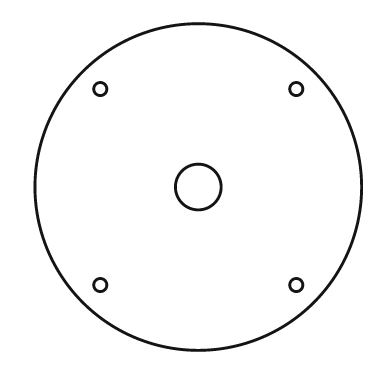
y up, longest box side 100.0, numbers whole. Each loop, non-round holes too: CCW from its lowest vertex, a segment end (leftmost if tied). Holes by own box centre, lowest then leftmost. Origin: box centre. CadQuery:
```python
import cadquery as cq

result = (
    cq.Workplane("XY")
    .moveTo(0.0, 0.0)
    .circle(50.0)
    .moveTo(-30.0, -30.0)
    .circle(2.0)
    .moveTo(30.0, -30.0)
    .circle(2.0)
    .moveTo(0.0, 0.0)
    .circle(7.0)
    .moveTo(-30.0, 30.0)
    .circle(2.0)
    .moveTo(30.0, 30.0)
    .circle(2.0)
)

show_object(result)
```